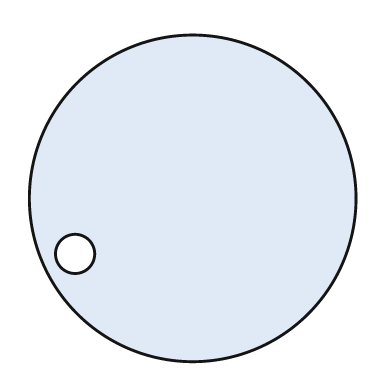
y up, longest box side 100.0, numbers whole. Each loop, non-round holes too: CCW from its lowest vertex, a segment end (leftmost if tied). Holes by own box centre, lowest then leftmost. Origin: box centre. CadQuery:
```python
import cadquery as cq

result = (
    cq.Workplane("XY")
    .moveTo(0.0, 0.0)
    .circle(50.0)
    .moveTo(-36.0, -17.0)
    .circle(6.0)
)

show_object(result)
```